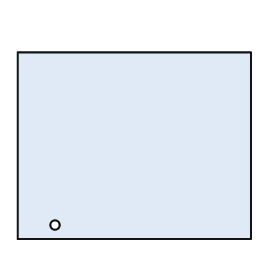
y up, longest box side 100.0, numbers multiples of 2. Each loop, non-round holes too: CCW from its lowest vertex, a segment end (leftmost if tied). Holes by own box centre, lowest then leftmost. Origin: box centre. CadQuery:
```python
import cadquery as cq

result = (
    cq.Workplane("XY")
    .moveTo(-50.0, -40.0)
    .lineTo(50.0, -40.0)
    .lineTo(50.0, 40.0)
    .lineTo(-50.0, 40.0)
    .close()
    .moveTo(-34.0, -34.0)
    .circle(2.0)
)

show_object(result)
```